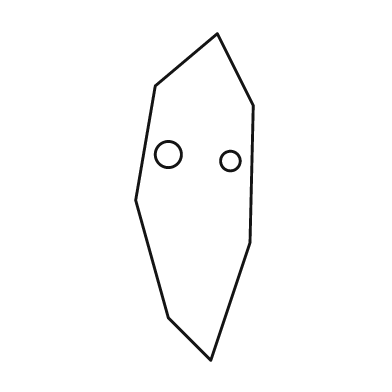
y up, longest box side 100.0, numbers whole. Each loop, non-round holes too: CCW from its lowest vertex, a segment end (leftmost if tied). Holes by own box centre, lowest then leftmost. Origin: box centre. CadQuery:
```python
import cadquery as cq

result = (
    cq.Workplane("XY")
    .moveTo(5.0, -50.0)
    .lineTo(17.0, -14.0)
    .lineTo(18.0, 28.0)
    .lineTo(7.0, 50.0)
    .lineTo(-12.0, 34.0)
    .lineTo(-18.0, -1.0)
    .lineTo(-8.0, -37.0)
    .close()
    .moveTo(11.0, 11.0)
    .circle(3.0)
    .moveTo(-8.0, 13.0)
    .circle(4.0)
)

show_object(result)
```